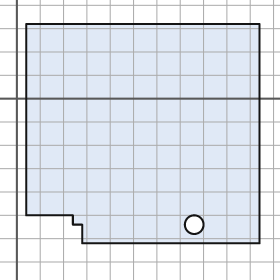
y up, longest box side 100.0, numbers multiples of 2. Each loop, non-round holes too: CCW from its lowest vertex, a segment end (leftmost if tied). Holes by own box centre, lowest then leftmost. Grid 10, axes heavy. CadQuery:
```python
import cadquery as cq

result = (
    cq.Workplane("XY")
    .moveTo(28.0, -62.0)
    .lineTo(104.0, -62.0)
    .lineTo(104.0, 32.0)
    .lineTo(4.0, 32.0)
    .lineTo(4.0, -50.0)
    .lineTo(24.0, -50.0)
    .lineTo(24.0, -54.0)
    .lineTo(28.0, -54.0)
    .close()
    .moveTo(76.0, -54.0)
    .circle(4.0)
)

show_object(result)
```